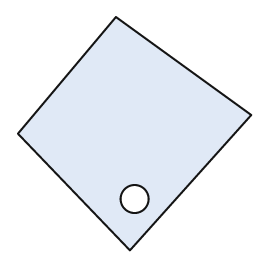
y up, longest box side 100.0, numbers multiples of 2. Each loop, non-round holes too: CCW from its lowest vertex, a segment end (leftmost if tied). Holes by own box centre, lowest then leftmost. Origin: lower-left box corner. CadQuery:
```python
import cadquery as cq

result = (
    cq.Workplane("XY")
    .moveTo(48.0, 0.0)
    .lineTo(100.0, 58.0)
    .lineTo(42.0, 100.0)
    .lineTo(0.0, 50.0)
    .close()
    .moveTo(50.0, 22.0)
    .circle(6.0)
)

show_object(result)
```